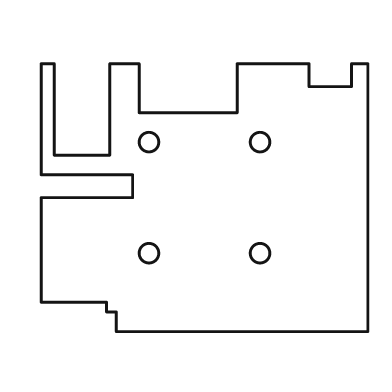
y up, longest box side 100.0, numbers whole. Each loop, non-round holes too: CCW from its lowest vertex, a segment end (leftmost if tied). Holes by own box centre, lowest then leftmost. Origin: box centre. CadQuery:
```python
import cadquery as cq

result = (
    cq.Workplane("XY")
    .moveTo(-27.0, -41.0)
    .lineTo(50.0, -41.0)
    .lineTo(50.0, 41.0)
    .lineTo(45.0, 41.0)
    .lineTo(45.0, 34.0)
    .lineTo(32.0, 34.0)
    .lineTo(32.0, 41.0)
    .lineTo(10.0, 41.0)
    .lineTo(10.0, 26.0)
    .lineTo(-20.0, 26.0)
    .lineTo(-20.0, 41.0)
    .lineTo(-29.0, 41.0)
    .lineTo(-29.0, 13.0)
    .lineTo(-46.0, 13.0)
    .lineTo(-46.0, 41.0)
    .lineTo(-50.0, 41.0)
    .lineTo(-50.0, 7.0)
    .lineTo(-22.0, 7.0)
    .lineTo(-22.0, 0.0)
    .lineTo(-50.0, 0.0)
    .lineTo(-50.0, -32.0)
    .lineTo(-30.0, -32.0)
    .lineTo(-30.0, -35.0)
    .lineTo(-27.0, -35.0)
    .close()
    .moveTo(-17.0, -17.0)
    .circle(3.0)
    .moveTo(17.0, -17.0)
    .circle(3.0)
    .moveTo(-17.0, 17.0)
    .circle(3.0)
    .moveTo(17.0, 17.0)
    .circle(3.0)
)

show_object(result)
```